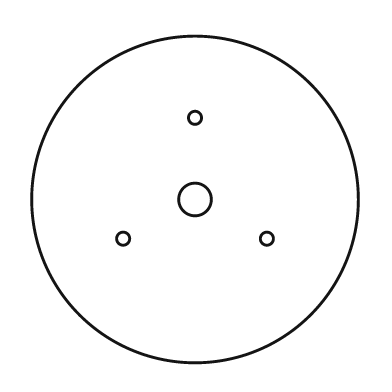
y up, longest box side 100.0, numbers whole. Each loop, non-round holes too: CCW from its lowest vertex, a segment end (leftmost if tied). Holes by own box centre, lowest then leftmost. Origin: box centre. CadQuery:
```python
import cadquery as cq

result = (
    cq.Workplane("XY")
    .moveTo(0.0, 0.0)
    .circle(50.0)
    .moveTo(-22.0, -12.0)
    .circle(2.0)
    .moveTo(22.0, -12.0)
    .circle(2.0)
    .moveTo(0.0, 0.0)
    .circle(5.0)
    .moveTo(0.0, 25.0)
    .circle(2.0)
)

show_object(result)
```